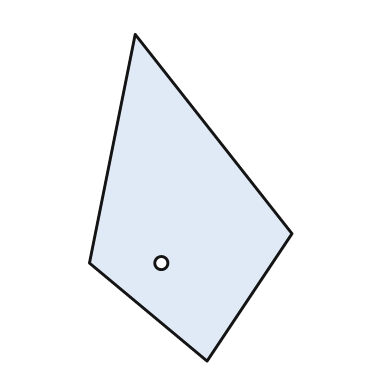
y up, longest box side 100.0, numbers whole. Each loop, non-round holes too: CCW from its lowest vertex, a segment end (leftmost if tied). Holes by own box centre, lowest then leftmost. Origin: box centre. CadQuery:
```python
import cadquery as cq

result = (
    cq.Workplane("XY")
    .moveTo(5.0, -50.0)
    .lineTo(31.0, -11.0)
    .lineTo(-17.0, 50.0)
    .lineTo(-31.0, -20.0)
    .close()
    .moveTo(-9.0, -20.0)
    .circle(2.0)
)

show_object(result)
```